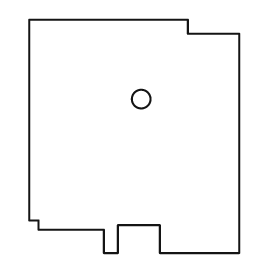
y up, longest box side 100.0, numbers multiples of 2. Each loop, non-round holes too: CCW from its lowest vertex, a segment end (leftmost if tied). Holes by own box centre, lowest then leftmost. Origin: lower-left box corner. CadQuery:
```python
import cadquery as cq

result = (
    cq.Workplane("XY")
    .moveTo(32.0, 0.0)
    .lineTo(38.0, 0.0)
    .lineTo(38.0, 12.0)
    .lineTo(56.0, 12.0)
    .lineTo(56.0, 0.0)
    .lineTo(90.0, 0.0)
    .lineTo(90.0, 94.0)
    .lineTo(68.0, 94.0)
    .lineTo(68.0, 100.0)
    .lineTo(0.0, 100.0)
    .lineTo(0.0, 14.0)
    .lineTo(4.0, 14.0)
    .lineTo(4.0, 10.0)
    .lineTo(32.0, 10.0)
    .close()
    .moveTo(48.0, 66.0)
    .circle(4.0)
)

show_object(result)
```